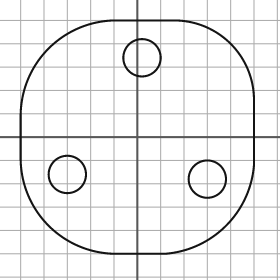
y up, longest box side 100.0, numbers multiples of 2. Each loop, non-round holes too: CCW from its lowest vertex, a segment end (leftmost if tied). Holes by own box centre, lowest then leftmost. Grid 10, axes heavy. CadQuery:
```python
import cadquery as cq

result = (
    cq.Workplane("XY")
    .moveTo(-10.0, -50.0)
    .lineTo(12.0, -50.0)
    .threePointArc((38.0, -38.0), (50.0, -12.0))
    .lineTo(50.0, 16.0)
    .threePointArc((40.0, 40.0), (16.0, 50.0))
    .lineTo(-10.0, 50.0)
    .threePointArc((-38.0, 38.0), (-50.0, 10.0))
    .lineTo(-50.0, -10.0)
    .threePointArc((-38.0, -38.0), (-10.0, -50.0))
    .close()
    .moveTo(30.0, -18.0)
    .circle(8.0)
    .moveTo(-30.0, -16.0)
    .circle(8.0)
    .moveTo(2.0, 34.0)
    .circle(8.0)
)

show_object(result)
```